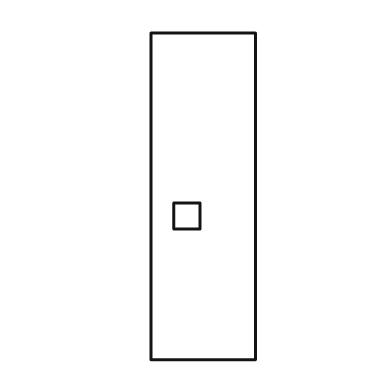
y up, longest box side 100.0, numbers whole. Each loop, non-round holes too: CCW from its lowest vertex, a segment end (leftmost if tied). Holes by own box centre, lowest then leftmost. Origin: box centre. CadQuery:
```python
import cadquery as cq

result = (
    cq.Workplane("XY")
    .moveTo(-16.0, -50.0)
    .lineTo(16.0, -50.0)
    .lineTo(16.0, 50.0)
    .lineTo(-16.0, 50.0)
    .close()
    .moveTo(-9.0, -10.0)
    .lineTo(-1.0, -10.0)
    .lineTo(-1.0, -2.0)
    .lineTo(-9.0, -2.0)
    .close()
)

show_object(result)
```